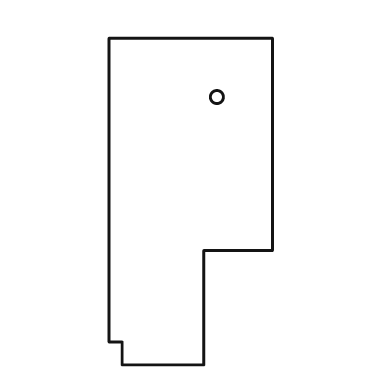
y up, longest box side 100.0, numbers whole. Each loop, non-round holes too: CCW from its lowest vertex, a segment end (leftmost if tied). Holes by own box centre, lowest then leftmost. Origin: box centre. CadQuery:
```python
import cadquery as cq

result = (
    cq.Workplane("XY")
    .moveTo(-21.0, -50.0)
    .lineTo(4.0, -50.0)
    .lineTo(4.0, -15.0)
    .lineTo(25.0, -15.0)
    .lineTo(25.0, 50.0)
    .lineTo(-25.0, 50.0)
    .lineTo(-25.0, -43.0)
    .lineTo(-21.0, -43.0)
    .close()
    .moveTo(8.0, 32.0)
    .circle(2.0)
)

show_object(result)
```